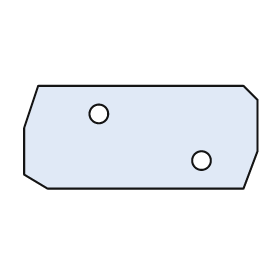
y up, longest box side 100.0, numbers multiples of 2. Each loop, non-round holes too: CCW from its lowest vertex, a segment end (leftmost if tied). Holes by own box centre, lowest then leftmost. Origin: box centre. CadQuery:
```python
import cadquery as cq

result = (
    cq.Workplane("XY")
    .moveTo(-40.0, -22.0)
    .lineTo(44.0, -22.0)
    .lineTo(50.0, -6.0)
    .lineTo(50.0, 16.0)
    .lineTo(44.0, 22.0)
    .lineTo(-44.0, 22.0)
    .lineTo(-50.0, 4.0)
    .lineTo(-50.0, -16.0)
    .close()
    .moveTo(26.0, -10.0)
    .circle(4.0)
    .moveTo(-18.0, 10.0)
    .circle(4.0)
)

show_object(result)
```